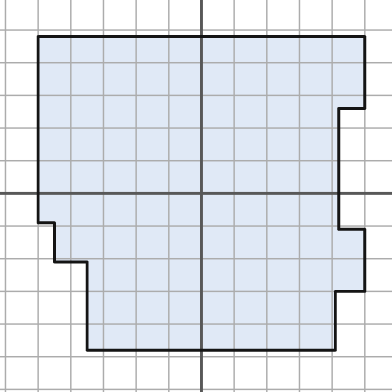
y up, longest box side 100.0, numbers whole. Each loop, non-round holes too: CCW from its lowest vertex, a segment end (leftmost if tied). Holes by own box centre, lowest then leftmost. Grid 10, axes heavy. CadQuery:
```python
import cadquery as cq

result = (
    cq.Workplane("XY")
    .moveTo(-35.0, -48.0)
    .lineTo(41.0, -48.0)
    .lineTo(41.0, -30.0)
    .lineTo(50.0, -30.0)
    .lineTo(50.0, -11.0)
    .lineTo(42.0, -11.0)
    .lineTo(42.0, 26.0)
    .lineTo(50.0, 26.0)
    .lineTo(50.0, 48.0)
    .lineTo(-50.0, 48.0)
    .lineTo(-50.0, -9.0)
    .lineTo(-45.0, -9.0)
    .lineTo(-45.0, -21.0)
    .lineTo(-35.0, -21.0)
    .close()
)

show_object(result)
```